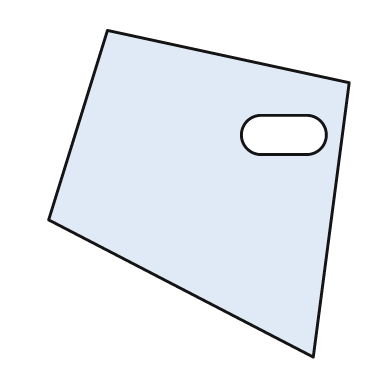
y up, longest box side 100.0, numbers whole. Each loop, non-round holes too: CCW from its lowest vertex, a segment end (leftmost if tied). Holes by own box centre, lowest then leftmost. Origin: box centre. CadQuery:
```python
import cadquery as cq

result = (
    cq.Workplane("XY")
    .moveTo(35.0, -50.0)
    .lineTo(46.0, 34.0)
    .lineTo(-28.0, 50.0)
    .lineTo(-46.0, -8.0)
    .close()
    .moveTo(19.0, 12.0)
    .lineTo(33.0, 12.0)
    .threePointArc((39.0, 18.0), (33.0, 24.0))
    .lineTo(19.0, 24.0)
    .threePointArc((13.0, 18.0), (19.0, 12.0))
    .close()
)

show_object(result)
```